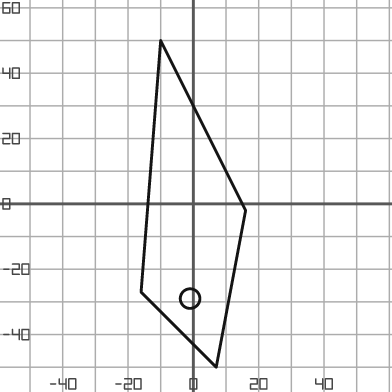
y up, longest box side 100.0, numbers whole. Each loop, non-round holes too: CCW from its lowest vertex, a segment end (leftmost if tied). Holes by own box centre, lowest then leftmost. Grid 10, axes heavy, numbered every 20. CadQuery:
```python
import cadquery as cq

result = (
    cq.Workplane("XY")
    .moveTo(7.0, -50.0)
    .lineTo(16.0, -2.0)
    .lineTo(-10.0, 50.0)
    .lineTo(-16.0, -27.0)
    .close()
    .moveTo(-1.0, -29.0)
    .circle(3.0)
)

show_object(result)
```